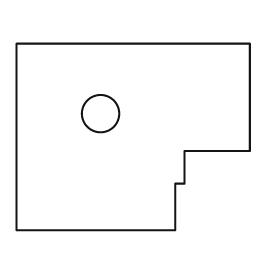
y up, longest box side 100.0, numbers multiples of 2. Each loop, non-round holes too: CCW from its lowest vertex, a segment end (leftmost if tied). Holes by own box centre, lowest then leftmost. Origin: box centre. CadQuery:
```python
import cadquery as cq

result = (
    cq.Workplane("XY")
    .moveTo(-50.0, -40.0)
    .lineTo(18.0, -40.0)
    .lineTo(18.0, -20.0)
    .lineTo(22.0, -20.0)
    .lineTo(22.0, -6.0)
    .lineTo(50.0, -6.0)
    .lineTo(50.0, 40.0)
    .lineTo(-50.0, 40.0)
    .close()
    .moveTo(-14.0, 10.0)
    .circle(8.0)
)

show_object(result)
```